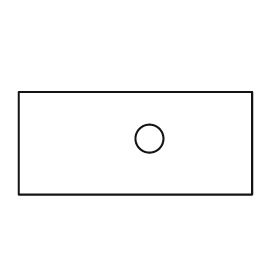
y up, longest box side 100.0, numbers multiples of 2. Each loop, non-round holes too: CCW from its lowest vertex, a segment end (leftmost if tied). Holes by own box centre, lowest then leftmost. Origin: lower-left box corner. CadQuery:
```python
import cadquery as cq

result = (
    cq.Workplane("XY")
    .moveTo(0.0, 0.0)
    .lineTo(100.0, 0.0)
    .lineTo(100.0, 44.0)
    .lineTo(0.0, 44.0)
    .close()
    .moveTo(56.0, 24.0)
    .circle(6.0)
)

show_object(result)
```